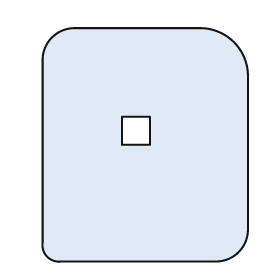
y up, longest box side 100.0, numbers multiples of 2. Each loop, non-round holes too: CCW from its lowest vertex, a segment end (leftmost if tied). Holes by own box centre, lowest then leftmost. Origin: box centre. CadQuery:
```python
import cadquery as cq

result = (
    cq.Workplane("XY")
    .moveTo(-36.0, -50.0)
    .lineTo(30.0, -50.0)
    .threePointArc((40.0, -46.0), (44.0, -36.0))
    .lineTo(44.0, 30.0)
    .threePointArc((38.0, 44.0), (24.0, 50.0))
    .lineTo(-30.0, 50.0)
    .threePointArc((-40.0, 46.0), (-44.0, 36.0))
    .lineTo(-44.0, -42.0)
    .threePointArc((-42.0, -48.0), (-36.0, -50.0))
    .close()
    .moveTo(-10.0, 0.0)
    .lineTo(2.0, 0.0)
    .lineTo(2.0, 12.0)
    .lineTo(-10.0, 12.0)
    .close()
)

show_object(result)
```